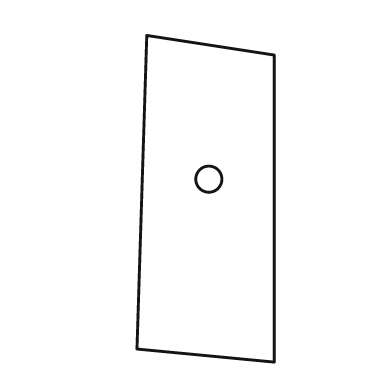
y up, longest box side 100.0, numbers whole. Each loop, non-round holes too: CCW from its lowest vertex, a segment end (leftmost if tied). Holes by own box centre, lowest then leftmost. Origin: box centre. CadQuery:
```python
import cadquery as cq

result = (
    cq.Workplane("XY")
    .moveTo(21.0, -50.0)
    .lineTo(21.0, 44.0)
    .lineTo(-18.0, 50.0)
    .lineTo(-21.0, -46.0)
    .close()
    .moveTo(1.0, 6.0)
    .circle(4.0)
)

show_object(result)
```